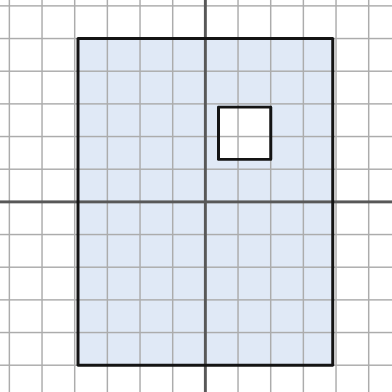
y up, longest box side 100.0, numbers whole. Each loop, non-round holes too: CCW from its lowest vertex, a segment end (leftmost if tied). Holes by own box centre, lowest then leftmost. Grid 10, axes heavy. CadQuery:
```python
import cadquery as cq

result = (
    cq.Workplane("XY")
    .moveTo(-39.0, -50.0)
    .lineTo(39.0, -50.0)
    .lineTo(39.0, 50.0)
    .lineTo(-39.0, 50.0)
    .close()
    .moveTo(4.0, 13.0)
    .lineTo(20.0, 13.0)
    .lineTo(20.0, 29.0)
    .lineTo(4.0, 29.0)
    .close()
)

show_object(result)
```